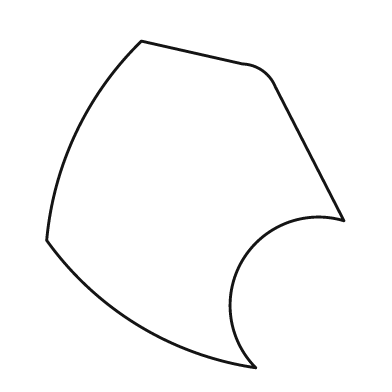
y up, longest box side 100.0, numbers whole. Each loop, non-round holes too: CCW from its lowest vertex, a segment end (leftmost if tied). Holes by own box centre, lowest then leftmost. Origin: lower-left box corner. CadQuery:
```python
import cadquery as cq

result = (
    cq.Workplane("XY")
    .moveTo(64.0, 0.0)
    .threePointArc((60.0, 33.0), (91.0, 45.0))
    .lineTo(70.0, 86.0)
    .threePointArc((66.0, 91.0), (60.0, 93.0))
    .lineTo(29.0, 100.0)
    .threePointArc((9.0, 72.0), (0.0, 39.0))
    .threePointArc((28.0, 13.0), (64.0, 0.0))
    .close()
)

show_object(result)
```